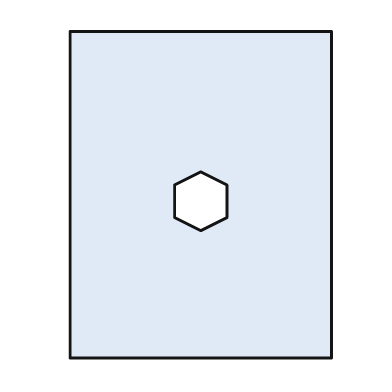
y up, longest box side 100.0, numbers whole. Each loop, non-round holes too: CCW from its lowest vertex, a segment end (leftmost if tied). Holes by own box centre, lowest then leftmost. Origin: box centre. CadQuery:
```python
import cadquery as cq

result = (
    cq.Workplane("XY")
    .moveTo(-40.0, -50.0)
    .lineTo(40.0, -50.0)
    .lineTo(40.0, 50.0)
    .lineTo(-40.0, 50.0)
    .close()
    .moveTo(0.0, -11.0)
    .lineTo(8.0, -7.0)
    .lineTo(8.0, 3.0)
    .lineTo(0.0, 7.0)
    .lineTo(-8.0, 3.0)
    .lineTo(-8.0, -7.0)
    .close()
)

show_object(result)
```